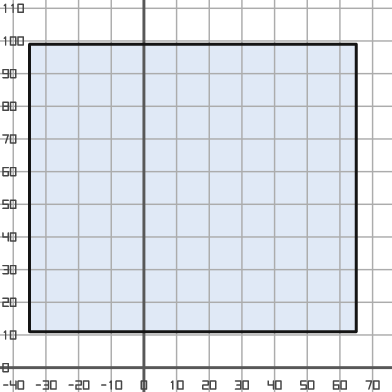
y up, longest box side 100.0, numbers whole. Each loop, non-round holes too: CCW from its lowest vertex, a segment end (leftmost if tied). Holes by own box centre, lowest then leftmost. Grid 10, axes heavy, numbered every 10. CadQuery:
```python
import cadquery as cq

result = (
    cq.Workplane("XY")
    .moveTo(-35.0, 11.0)
    .lineTo(65.0, 11.0)
    .lineTo(65.0, 99.0)
    .lineTo(-35.0, 99.0)
    .close()
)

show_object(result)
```